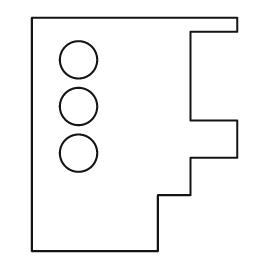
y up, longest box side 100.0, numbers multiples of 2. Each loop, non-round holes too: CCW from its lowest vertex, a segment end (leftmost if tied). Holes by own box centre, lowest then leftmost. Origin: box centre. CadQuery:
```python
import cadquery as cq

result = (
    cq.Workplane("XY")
    .moveTo(-44.0, -50.0)
    .lineTo(10.0, -50.0)
    .lineTo(10.0, -26.0)
    .lineTo(24.0, -26.0)
    .lineTo(24.0, -10.0)
    .lineTo(44.0, -10.0)
    .lineTo(44.0, 6.0)
    .lineTo(24.0, 6.0)
    .lineTo(24.0, 44.0)
    .lineTo(44.0, 44.0)
    .lineTo(44.0, 50.0)
    .lineTo(-44.0, 50.0)
    .close()
    .moveTo(-24.0, -8.0)
    .circle(8.0)
    .moveTo(-24.0, 12.0)
    .circle(8.0)
    .moveTo(-24.0, 32.0)
    .circle(8.0)
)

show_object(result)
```